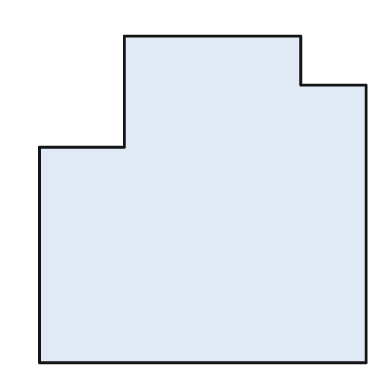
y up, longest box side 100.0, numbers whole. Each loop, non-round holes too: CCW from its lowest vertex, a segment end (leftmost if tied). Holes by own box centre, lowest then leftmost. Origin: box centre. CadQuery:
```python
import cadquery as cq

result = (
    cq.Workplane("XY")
    .moveTo(-50.0, -50.0)
    .lineTo(50.0, -50.0)
    .lineTo(50.0, 35.0)
    .lineTo(30.0, 35.0)
    .lineTo(30.0, 50.0)
    .lineTo(-24.0, 50.0)
    .lineTo(-24.0, 16.0)
    .lineTo(-50.0, 16.0)
    .close()
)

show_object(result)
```